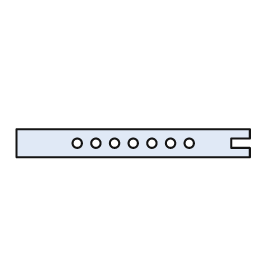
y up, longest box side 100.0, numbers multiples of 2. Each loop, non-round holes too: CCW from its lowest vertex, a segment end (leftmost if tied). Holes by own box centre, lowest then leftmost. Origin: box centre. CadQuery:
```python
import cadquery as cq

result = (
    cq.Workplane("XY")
    .moveTo(-50.0, -6.0)
    .lineTo(50.0, -6.0)
    .lineTo(50.0, -2.0)
    .lineTo(42.0, -2.0)
    .lineTo(42.0, 2.0)
    .lineTo(50.0, 2.0)
    .lineTo(50.0, 6.0)
    .lineTo(-50.0, 6.0)
    .close()
    .moveTo(-24.0, 0.0)
    .circle(2.0)
    .moveTo(-16.0, 0.0)
    .circle(2.0)
    .moveTo(-8.0, 0.0)
    .circle(2.0)
    .moveTo(0.0, 0.0)
    .circle(2.0)
    .moveTo(8.0, 0.0)
    .circle(2.0)
    .moveTo(16.0, 0.0)
    .circle(2.0)
    .moveTo(24.0, 0.0)
    .circle(2.0)
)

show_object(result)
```